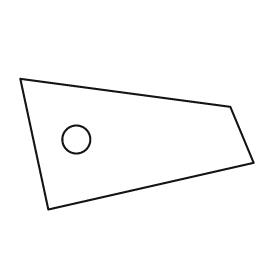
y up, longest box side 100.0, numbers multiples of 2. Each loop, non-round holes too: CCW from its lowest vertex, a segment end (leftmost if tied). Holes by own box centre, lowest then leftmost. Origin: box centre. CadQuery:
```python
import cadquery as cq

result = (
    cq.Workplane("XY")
    .moveTo(-38.0, -28.0)
    .lineTo(50.0, -8.0)
    .lineTo(40.0, 16.0)
    .lineTo(-50.0, 28.0)
    .close()
    .moveTo(-26.0, 2.0)
    .circle(6.0)
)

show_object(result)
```